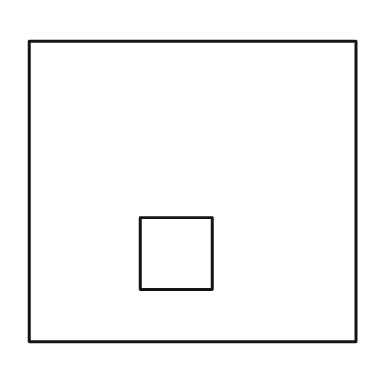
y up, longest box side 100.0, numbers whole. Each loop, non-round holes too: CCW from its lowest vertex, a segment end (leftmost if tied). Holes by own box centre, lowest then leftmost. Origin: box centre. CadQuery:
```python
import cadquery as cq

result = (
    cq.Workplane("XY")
    .moveTo(-50.0, -46.0)
    .lineTo(50.0, -46.0)
    .lineTo(50.0, 46.0)
    .lineTo(-50.0, 46.0)
    .close()
    .moveTo(-16.0, -30.0)
    .lineTo(6.0, -30.0)
    .lineTo(6.0, -8.0)
    .lineTo(-16.0, -8.0)
    .close()
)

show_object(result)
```